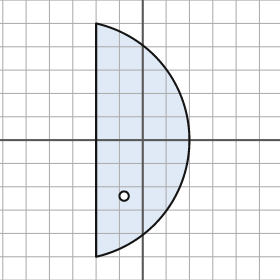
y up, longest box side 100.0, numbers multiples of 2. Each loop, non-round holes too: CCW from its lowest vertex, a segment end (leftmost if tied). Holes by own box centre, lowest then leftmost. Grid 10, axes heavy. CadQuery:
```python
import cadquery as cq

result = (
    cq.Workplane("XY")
    .moveTo(-20.0, -50.0)
    .threePointArc((20.0, 0.0), (-20.0, 50.0))
    .close()
    .moveTo(-8.0, -24.0)
    .circle(2.0)
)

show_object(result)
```